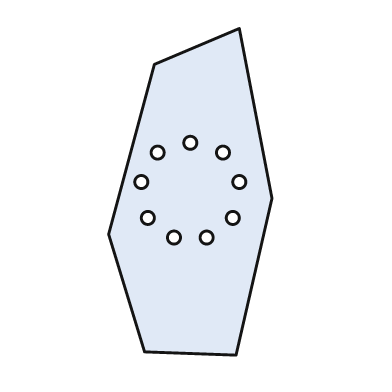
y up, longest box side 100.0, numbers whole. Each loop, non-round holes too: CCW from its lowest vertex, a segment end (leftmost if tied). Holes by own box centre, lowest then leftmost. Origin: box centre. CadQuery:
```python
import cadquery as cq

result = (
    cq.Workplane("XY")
    .moveTo(14.0, -50.0)
    .lineTo(25.0, -2.0)
    .lineTo(15.0, 50.0)
    .lineTo(-11.0, 39.0)
    .lineTo(-25.0, -13.0)
    .lineTo(-14.0, -49.0)
    .close()
    .moveTo(-5.0, -14.0)
    .circle(2.0)
    .moveTo(5.0, -14.0)
    .circle(2.0)
    .moveTo(-13.0, -8.0)
    .circle(2.0)
    .moveTo(13.0, -8.0)
    .circle(2.0)
    .moveTo(-15.0, 3.0)
    .circle(2.0)
    .moveTo(15.0, 3.0)
    .circle(2.0)
    .moveTo(-10.0, 12.0)
    .circle(2.0)
    .moveTo(10.0, 12.0)
    .circle(2.0)
    .moveTo(0.0, 15.0)
    .circle(2.0)
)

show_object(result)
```